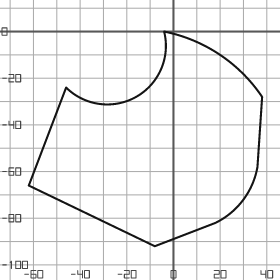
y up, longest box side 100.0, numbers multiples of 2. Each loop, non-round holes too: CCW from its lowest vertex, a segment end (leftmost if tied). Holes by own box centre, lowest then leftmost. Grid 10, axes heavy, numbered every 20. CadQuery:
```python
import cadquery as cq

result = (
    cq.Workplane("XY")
    .moveTo(-8.0, -92.0)
    .lineTo(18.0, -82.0)
    .threePointArc((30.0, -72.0), (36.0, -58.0))
    .lineTo(38.0, -28.0)
    .threePointArc((20.0, -10.0), (-4.0, 0.0))
    .threePointArc((-16.0, -28.0), (-46.0, -24.0))
    .lineTo(-62.0, -66.0)
    .close()
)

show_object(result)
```